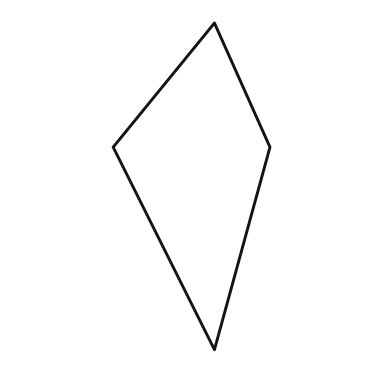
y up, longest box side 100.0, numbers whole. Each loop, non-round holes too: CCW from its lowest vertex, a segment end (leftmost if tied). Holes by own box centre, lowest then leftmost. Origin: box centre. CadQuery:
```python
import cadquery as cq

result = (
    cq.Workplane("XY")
    .moveTo(7.0, -50.0)
    .lineTo(24.0, 12.0)
    .lineTo(7.0, 50.0)
    .lineTo(-24.0, 12.0)
    .close()
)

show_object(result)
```